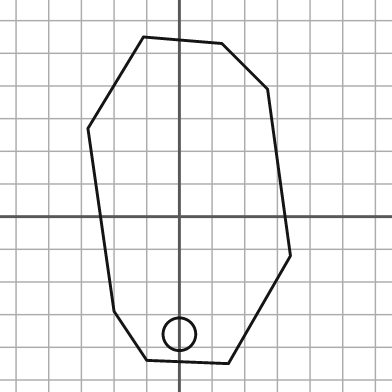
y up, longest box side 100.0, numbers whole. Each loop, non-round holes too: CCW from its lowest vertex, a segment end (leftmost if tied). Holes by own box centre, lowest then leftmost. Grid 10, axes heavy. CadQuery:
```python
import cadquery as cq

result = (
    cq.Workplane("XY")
    .moveTo(15.0, -45.0)
    .lineTo(34.0, -12.0)
    .lineTo(27.0, 39.0)
    .lineTo(13.0, 53.0)
    .lineTo(-11.0, 55.0)
    .lineTo(-28.0, 27.0)
    .lineTo(-20.0, -29.0)
    .lineTo(-10.0, -44.0)
    .close()
    .moveTo(0.0, -36.0)
    .circle(5.0)
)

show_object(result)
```